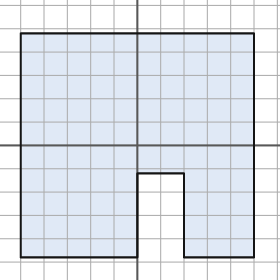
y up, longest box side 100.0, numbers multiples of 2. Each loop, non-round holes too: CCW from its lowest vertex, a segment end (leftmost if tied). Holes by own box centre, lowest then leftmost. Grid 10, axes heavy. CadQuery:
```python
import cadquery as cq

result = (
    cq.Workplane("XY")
    .moveTo(-50.0, -48.0)
    .lineTo(0.0, -48.0)
    .lineTo(0.0, -12.0)
    .lineTo(20.0, -12.0)
    .lineTo(20.0, -48.0)
    .lineTo(50.0, -48.0)
    .lineTo(50.0, 48.0)
    .lineTo(-50.0, 48.0)
    .close()
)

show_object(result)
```